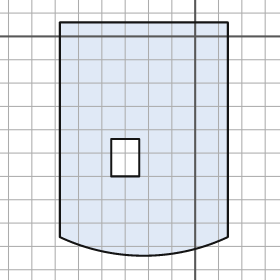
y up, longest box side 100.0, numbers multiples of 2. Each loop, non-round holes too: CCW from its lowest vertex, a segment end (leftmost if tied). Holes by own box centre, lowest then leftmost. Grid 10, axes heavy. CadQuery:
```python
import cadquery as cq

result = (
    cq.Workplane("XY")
    .moveTo(-58.0, -86.0)
    .threePointArc((-22.0, -94.0), (14.0, -86.0))
    .lineTo(14.0, 6.0)
    .lineTo(-58.0, 6.0)
    .close()
    .moveTo(-36.0, -60.0)
    .lineTo(-24.0, -60.0)
    .lineTo(-24.0, -44.0)
    .lineTo(-36.0, -44.0)
    .close()
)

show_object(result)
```